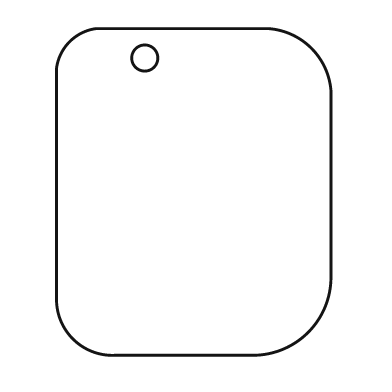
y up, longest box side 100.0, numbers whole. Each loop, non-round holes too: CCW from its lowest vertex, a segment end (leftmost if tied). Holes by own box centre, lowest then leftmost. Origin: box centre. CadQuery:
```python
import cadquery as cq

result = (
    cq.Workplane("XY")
    .moveTo(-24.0, -50.0)
    .lineTo(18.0, -50.0)
    .threePointArc((35.0, -43.0), (42.0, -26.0))
    .lineTo(42.0, 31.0)
    .threePointArc((36.0, 44.0), (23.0, 50.0))
    .lineTo(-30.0, 50.0)
    .threePointArc((-38.0, 46.0), (-42.0, 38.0))
    .lineTo(-42.0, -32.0)
    .threePointArc((-37.0, -45.0), (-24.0, -50.0))
    .close()
    .moveTo(-15.0, 41.0)
    .circle(4.0)
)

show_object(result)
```